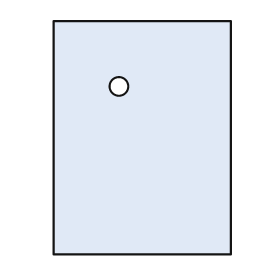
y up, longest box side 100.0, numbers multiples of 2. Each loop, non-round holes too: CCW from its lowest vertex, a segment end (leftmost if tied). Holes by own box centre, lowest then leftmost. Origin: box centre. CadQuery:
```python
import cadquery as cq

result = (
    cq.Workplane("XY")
    .moveTo(-38.0, -50.0)
    .lineTo(38.0, -50.0)
    .lineTo(38.0, 50.0)
    .lineTo(-38.0, 50.0)
    .close()
    .moveTo(-10.0, 22.0)
    .circle(4.0)
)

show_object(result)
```